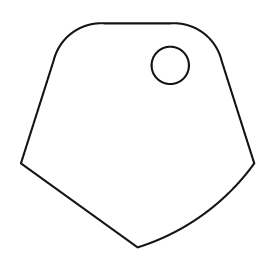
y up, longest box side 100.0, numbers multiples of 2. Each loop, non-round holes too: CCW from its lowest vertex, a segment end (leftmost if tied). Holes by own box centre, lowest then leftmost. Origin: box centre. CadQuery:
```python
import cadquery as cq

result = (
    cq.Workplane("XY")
    .moveTo(0.0, -48.0)
    .threePointArc((28.0, -34.0), (50.0, -12.0))
    .lineTo(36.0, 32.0)
    .threePointArc((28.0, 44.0), (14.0, 48.0))
    .lineTo(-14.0, 48.0)
    .threePointArc((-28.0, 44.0), (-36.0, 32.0))
    .lineTo(-50.0, -12.0)
    .close()
    .moveTo(14.0, 30.0)
    .circle(8.0)
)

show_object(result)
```